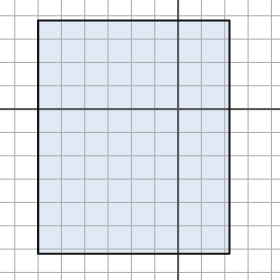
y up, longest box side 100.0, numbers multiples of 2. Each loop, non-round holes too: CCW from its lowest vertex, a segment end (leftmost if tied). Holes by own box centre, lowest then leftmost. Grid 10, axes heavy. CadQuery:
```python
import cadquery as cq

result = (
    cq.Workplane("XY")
    .moveTo(-60.0, -62.0)
    .lineTo(22.0, -62.0)
    .lineTo(22.0, 38.0)
    .lineTo(-60.0, 38.0)
    .close()
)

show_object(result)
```